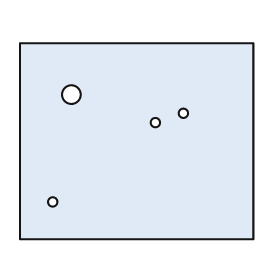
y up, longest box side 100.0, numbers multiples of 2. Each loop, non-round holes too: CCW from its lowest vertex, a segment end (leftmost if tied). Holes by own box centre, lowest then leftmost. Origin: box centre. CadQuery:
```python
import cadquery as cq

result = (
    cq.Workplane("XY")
    .moveTo(-50.0, -42.0)
    .lineTo(50.0, -42.0)
    .lineTo(50.0, 42.0)
    .lineTo(-50.0, 42.0)
    .close()
    .moveTo(-36.0, -26.0)
    .circle(2.0)
    .moveTo(8.0, 8.0)
    .circle(2.0)
    .moveTo(20.0, 12.0)
    .circle(2.0)
    .moveTo(-28.0, 20.0)
    .circle(4.0)
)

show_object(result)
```